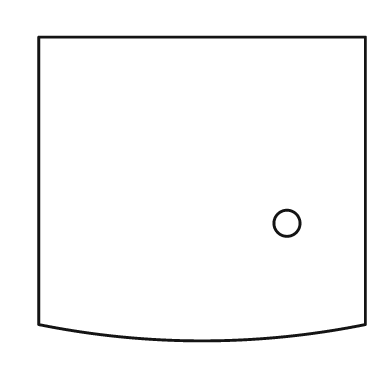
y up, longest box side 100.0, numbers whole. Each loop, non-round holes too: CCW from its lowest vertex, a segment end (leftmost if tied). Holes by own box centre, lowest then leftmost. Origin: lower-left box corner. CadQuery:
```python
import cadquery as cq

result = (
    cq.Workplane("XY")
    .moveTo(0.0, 5.0)
    .threePointArc((50.0, 0.0), (100.0, 5.0))
    .lineTo(100.0, 93.0)
    .lineTo(0.0, 93.0)
    .close()
    .moveTo(76.0, 36.0)
    .circle(4.0)
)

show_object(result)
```